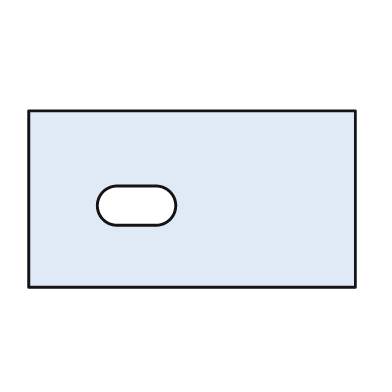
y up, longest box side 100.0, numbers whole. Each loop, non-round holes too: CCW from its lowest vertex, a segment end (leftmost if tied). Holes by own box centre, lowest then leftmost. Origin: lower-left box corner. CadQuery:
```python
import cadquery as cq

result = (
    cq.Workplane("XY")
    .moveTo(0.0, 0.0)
    .lineTo(100.0, 0.0)
    .lineTo(100.0, 54.0)
    .lineTo(0.0, 54.0)
    .close()
    .moveTo(27.0, 19.0)
    .lineTo(39.0, 19.0)
    .threePointArc((45.0, 25.0), (39.0, 31.0))
    .lineTo(27.0, 31.0)
    .threePointArc((21.0, 25.0), (27.0, 19.0))
    .close()
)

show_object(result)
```